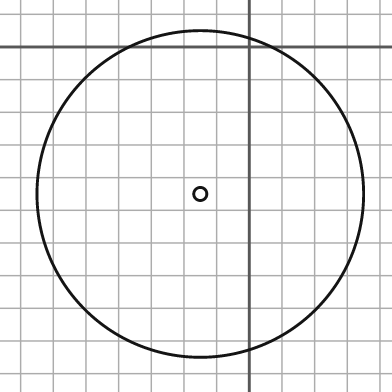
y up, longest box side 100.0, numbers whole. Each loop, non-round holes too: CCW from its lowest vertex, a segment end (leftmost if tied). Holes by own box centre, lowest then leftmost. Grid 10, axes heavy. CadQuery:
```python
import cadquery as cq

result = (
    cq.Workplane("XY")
    .moveTo(-15.0, -45.0)
    .circle(50.0)
    .moveTo(-15.0, -45.0)
    .circle(2.0)
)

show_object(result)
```